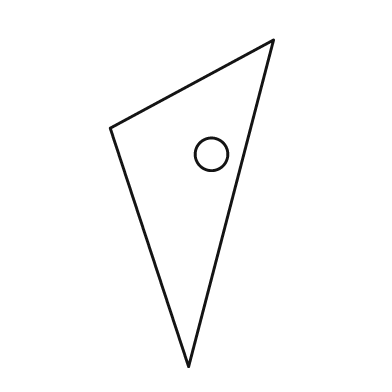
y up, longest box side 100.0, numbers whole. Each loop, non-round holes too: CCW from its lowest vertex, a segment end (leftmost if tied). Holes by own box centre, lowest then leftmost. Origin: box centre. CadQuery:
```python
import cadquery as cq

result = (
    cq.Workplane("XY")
    .moveTo(-1.0, -50.0)
    .lineTo(25.0, 50.0)
    .lineTo(-25.0, 23.0)
    .close()
    .moveTo(6.0, 15.0)
    .circle(5.0)
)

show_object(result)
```